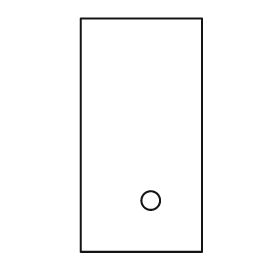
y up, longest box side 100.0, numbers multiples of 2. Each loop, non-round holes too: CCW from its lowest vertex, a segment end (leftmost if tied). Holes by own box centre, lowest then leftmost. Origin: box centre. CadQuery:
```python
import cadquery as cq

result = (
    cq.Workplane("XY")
    .moveTo(-26.0, -50.0)
    .lineTo(26.0, -50.0)
    .lineTo(26.0, 50.0)
    .lineTo(-26.0, 50.0)
    .close()
    .moveTo(4.0, -28.0)
    .circle(4.0)
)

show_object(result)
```